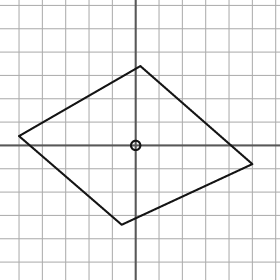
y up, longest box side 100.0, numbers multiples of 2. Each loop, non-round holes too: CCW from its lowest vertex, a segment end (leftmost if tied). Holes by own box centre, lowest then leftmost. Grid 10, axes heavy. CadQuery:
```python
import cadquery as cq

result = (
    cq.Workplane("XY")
    .moveTo(-6.0, -34.0)
    .lineTo(50.0, -8.0)
    .lineTo(2.0, 34.0)
    .lineTo(-50.0, 4.0)
    .close()
    .moveTo(0.0, 0.0)
    .circle(2.0)
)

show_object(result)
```